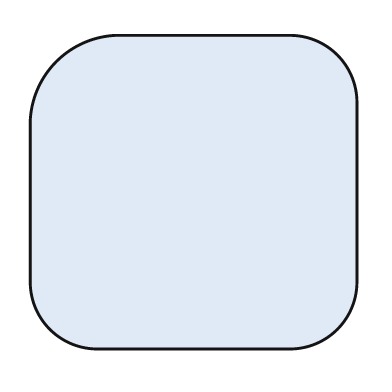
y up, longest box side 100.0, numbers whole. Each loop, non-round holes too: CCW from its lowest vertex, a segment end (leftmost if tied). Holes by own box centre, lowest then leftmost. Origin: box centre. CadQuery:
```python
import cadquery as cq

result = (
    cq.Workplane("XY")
    .moveTo(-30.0, -48.0)
    .lineTo(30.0, -48.0)
    .threePointArc((44.0, -42.0), (50.0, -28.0))
    .lineTo(50.0, 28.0)
    .threePointArc((44.0, 42.0), (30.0, 48.0))
    .lineTo(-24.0, 48.0)
    .threePointArc((-42.0, 40.0), (-50.0, 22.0))
    .lineTo(-50.0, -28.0)
    .threePointArc((-44.0, -42.0), (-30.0, -48.0))
    .close()
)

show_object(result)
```